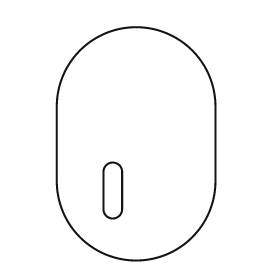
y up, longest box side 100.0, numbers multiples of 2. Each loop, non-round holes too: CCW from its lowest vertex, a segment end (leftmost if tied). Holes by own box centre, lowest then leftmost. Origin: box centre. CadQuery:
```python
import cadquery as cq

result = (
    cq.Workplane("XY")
    .moveTo(-34.0, -16.0)
    .threePointArc((0.0, -50.0), (34.0, -16.0))
    .lineTo(34.0, 16.0)
    .threePointArc((0.0, 50.0), (-34.0, 16.0))
    .close()
    .moveTo(-14.0, -28.0)
    .threePointArc((-10.0, -32.0), (-6.0, -28.0))
    .lineTo(-6.0, -12.0)
    .threePointArc((-10.0, -8.0), (-14.0, -12.0))
    .close()
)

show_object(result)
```